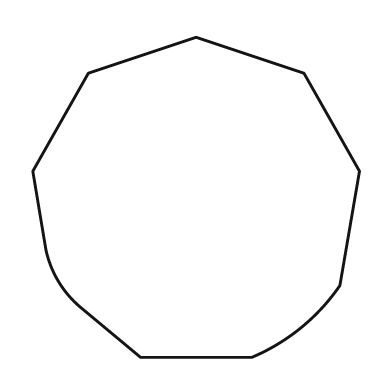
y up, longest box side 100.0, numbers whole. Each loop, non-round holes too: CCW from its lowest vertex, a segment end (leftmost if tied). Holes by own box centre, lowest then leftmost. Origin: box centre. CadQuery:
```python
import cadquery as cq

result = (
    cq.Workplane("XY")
    .moveTo(-17.0, -49.0)
    .lineTo(17.0, -49.0)
    .threePointArc((32.0, -40.0), (44.0, -27.0))
    .lineTo(50.0, 8.0)
    .lineTo(33.0, 38.0)
    .lineTo(0.0, 49.0)
    .lineTo(-33.0, 38.0)
    .lineTo(-50.0, 8.0)
    .lineTo(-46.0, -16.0)
    .threePointArc((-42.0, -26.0), (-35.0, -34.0))
    .close()
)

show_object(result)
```